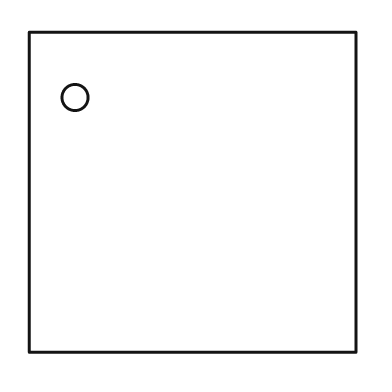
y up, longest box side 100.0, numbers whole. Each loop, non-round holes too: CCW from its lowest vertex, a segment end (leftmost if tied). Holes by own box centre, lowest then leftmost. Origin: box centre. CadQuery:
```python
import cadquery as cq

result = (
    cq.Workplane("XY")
    .moveTo(-50.0, -49.0)
    .lineTo(50.0, -49.0)
    .lineTo(50.0, 49.0)
    .lineTo(-50.0, 49.0)
    .close()
    .moveTo(-36.0, 29.0)
    .circle(4.0)
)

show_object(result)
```